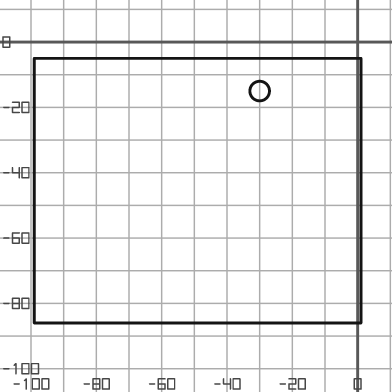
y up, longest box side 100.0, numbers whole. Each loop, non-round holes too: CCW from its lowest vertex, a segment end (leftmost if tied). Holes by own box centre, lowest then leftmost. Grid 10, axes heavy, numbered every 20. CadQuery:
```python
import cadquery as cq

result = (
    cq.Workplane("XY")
    .moveTo(-99.0, -86.0)
    .lineTo(1.0, -86.0)
    .lineTo(1.0, -5.0)
    .lineTo(-99.0, -5.0)
    .close()
    .moveTo(-30.0, -15.0)
    .circle(3.0)
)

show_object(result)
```